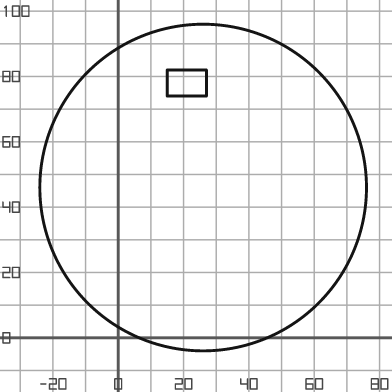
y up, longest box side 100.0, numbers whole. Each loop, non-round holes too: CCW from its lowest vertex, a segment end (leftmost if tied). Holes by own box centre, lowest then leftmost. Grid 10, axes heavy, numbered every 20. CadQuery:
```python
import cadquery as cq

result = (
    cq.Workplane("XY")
    .moveTo(26.0, 46.0)
    .circle(50.0)
    .moveTo(15.0, 74.0)
    .lineTo(27.0, 74.0)
    .lineTo(27.0, 82.0)
    .lineTo(15.0, 82.0)
    .close()
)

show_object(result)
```